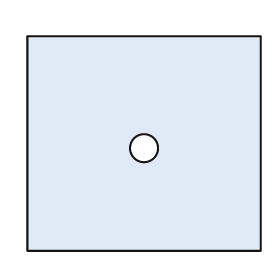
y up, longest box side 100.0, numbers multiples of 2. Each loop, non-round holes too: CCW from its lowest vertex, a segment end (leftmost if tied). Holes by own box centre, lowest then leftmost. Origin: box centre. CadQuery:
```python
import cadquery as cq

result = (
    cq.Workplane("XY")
    .moveTo(-50.0, -46.0)
    .lineTo(50.0, -46.0)
    .lineTo(50.0, 46.0)
    .lineTo(-50.0, 46.0)
    .close()
    .moveTo(0.0, -2.0)
    .circle(6.0)
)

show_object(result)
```